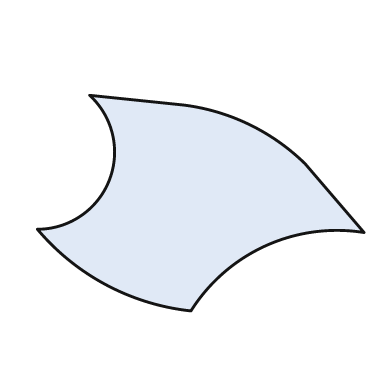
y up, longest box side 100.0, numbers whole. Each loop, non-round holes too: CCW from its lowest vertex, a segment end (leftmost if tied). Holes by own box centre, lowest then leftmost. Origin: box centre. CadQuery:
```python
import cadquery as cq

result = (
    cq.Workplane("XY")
    .moveTo(-3.0, -33.0)
    .threePointArc((20.0, -13.0), (50.0, -9.0))
    .lineTo(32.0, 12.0)
    .threePointArc((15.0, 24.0), (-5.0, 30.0))
    .lineTo(-34.0, 33.0)
    .threePointArc((-28.0, 7.0), (-50.0, -8.0))
    .threePointArc((-29.0, -25.0), (-3.0, -33.0))
    .close()
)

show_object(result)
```